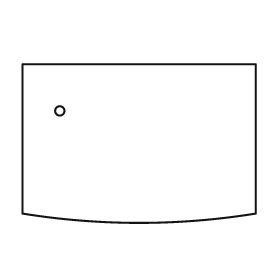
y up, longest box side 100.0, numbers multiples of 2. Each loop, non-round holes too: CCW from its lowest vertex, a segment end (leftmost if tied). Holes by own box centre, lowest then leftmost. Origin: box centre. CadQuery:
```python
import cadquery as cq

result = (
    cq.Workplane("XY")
    .moveTo(-50.0, -30.0)
    .threePointArc((0.0, -34.0), (50.0, -30.0))
    .lineTo(50.0, 34.0)
    .lineTo(-50.0, 34.0)
    .close()
    .moveTo(-34.0, 14.0)
    .circle(2.0)
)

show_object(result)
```